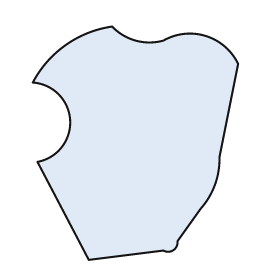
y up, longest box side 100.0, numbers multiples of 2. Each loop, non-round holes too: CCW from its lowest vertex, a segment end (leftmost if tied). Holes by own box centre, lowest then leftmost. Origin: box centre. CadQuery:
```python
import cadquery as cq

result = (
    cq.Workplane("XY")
    .moveTo(-20.0, -50.0)
    .lineTo(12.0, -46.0)
    .threePointArc((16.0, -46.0), (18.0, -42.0))
    .lineTo(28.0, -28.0)
    .threePointArc((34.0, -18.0), (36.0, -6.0))
    .lineTo(44.0, 34.0)
    .threePointArc((30.0, 46.0), (12.0, 44.0))
    .threePointArc((0.0, 44.0), (-10.0, 50.0))
    .threePointArc((-30.0, 42.0), (-44.0, 26.0))
    .threePointArc((-28.0, 10.0), (-42.0, -8.0))
    .close()
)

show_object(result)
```